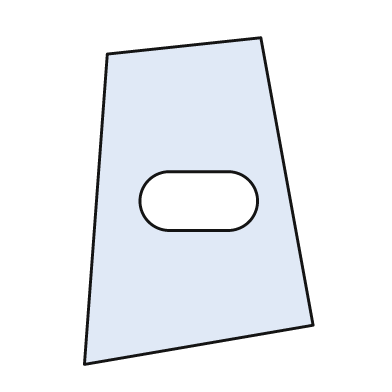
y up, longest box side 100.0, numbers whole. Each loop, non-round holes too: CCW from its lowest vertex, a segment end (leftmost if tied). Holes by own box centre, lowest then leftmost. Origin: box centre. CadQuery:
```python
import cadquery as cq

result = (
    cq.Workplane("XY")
    .moveTo(-35.0, -50.0)
    .lineTo(35.0, -38.0)
    .lineTo(19.0, 50.0)
    .lineTo(-28.0, 45.0)
    .close()
    .moveTo(-9.0, -9.0)
    .lineTo(9.0, -9.0)
    .threePointArc((18.0, 0.0), (9.0, 9.0))
    .lineTo(-9.0, 9.0)
    .threePointArc((-18.0, 0.0), (-9.0, -9.0))
    .close()
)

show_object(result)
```